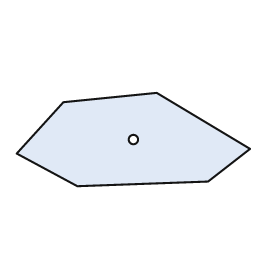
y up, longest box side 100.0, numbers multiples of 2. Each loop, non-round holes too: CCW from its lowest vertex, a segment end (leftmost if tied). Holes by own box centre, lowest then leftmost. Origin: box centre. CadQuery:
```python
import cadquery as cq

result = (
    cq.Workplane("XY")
    .moveTo(-24.0, -20.0)
    .lineTo(32.0, -18.0)
    .lineTo(50.0, -4.0)
    .lineTo(10.0, 20.0)
    .lineTo(-30.0, 16.0)
    .lineTo(-50.0, -6.0)
    .close()
    .moveTo(0.0, 0.0)
    .circle(2.0)
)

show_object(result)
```